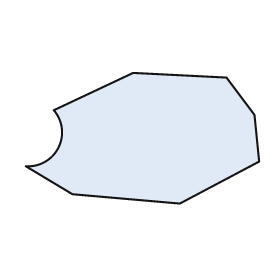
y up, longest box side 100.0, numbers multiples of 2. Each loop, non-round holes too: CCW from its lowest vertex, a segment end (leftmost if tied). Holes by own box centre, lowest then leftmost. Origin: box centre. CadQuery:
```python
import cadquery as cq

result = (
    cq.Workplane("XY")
    .moveTo(16.0, -28.0)
    .lineTo(50.0, -10.0)
    .lineTo(48.0, 10.0)
    .lineTo(36.0, 26.0)
    .lineTo(-4.0, 28.0)
    .lineTo(-38.0, 12.0)
    .threePointArc((-36.0, -4.0), (-50.0, -12.0))
    .lineTo(-30.0, -24.0)
    .close()
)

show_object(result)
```